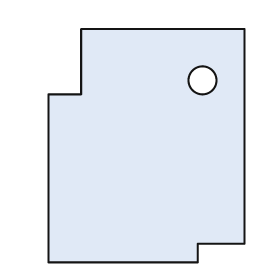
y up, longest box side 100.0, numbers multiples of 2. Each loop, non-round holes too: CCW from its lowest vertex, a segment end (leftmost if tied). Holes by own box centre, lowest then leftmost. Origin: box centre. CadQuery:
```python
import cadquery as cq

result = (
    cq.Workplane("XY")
    .moveTo(-42.0, -50.0)
    .lineTo(22.0, -50.0)
    .lineTo(22.0, -42.0)
    .lineTo(42.0, -42.0)
    .lineTo(42.0, 50.0)
    .lineTo(-28.0, 50.0)
    .lineTo(-28.0, 22.0)
    .lineTo(-42.0, 22.0)
    .close()
    .moveTo(24.0, 28.0)
    .circle(6.0)
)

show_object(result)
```